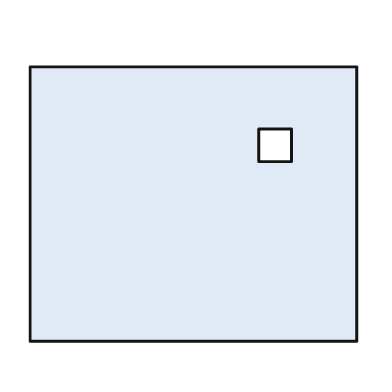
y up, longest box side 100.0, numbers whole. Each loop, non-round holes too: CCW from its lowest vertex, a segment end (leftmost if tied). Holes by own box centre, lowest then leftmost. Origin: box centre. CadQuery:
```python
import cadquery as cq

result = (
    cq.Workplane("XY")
    .moveTo(-50.0, -42.0)
    .lineTo(50.0, -42.0)
    .lineTo(50.0, 42.0)
    .lineTo(-50.0, 42.0)
    .close()
    .moveTo(20.0, 13.0)
    .lineTo(30.0, 13.0)
    .lineTo(30.0, 23.0)
    .lineTo(20.0, 23.0)
    .close()
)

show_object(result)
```